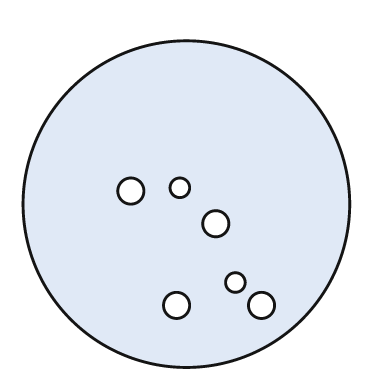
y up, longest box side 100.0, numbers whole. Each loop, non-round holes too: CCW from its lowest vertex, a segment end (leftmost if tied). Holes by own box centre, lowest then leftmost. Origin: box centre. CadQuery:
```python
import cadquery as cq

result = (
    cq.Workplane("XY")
    .moveTo(0.0, 0.0)
    .circle(50.0)
    .moveTo(-3.0, -31.0)
    .circle(4.0)
    .moveTo(23.0, -31.0)
    .circle(4.0)
    .moveTo(15.0, -24.0)
    .circle(3.0)
    .moveTo(9.0, -6.0)
    .circle(4.0)
    .moveTo(-17.0, 4.0)
    .circle(4.0)
    .moveTo(-2.0, 5.0)
    .circle(3.0)
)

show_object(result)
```